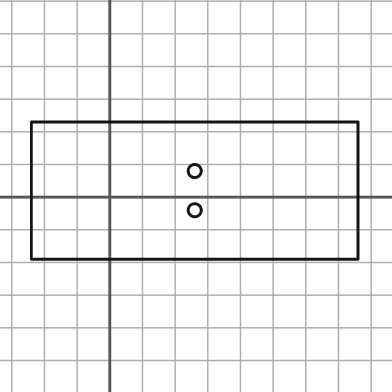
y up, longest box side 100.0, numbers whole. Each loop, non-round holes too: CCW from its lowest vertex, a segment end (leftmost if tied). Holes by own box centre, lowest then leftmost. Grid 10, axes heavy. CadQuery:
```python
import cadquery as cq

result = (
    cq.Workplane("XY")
    .moveTo(-24.0, -19.0)
    .lineTo(76.0, -19.0)
    .lineTo(76.0, 23.0)
    .lineTo(-24.0, 23.0)
    .close()
    .moveTo(26.0, -4.0)
    .circle(2.0)
    .moveTo(26.0, 8.0)
    .circle(2.0)
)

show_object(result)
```